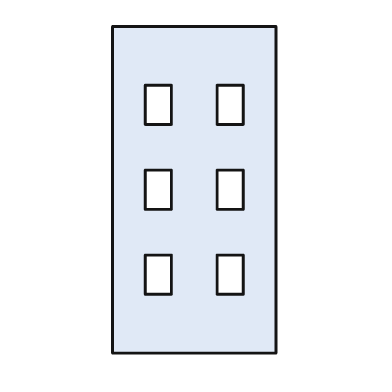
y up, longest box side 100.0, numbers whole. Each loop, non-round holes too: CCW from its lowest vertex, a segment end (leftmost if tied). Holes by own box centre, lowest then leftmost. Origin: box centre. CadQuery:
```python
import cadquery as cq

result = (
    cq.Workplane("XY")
    .moveTo(-25.0, -50.0)
    .lineTo(25.0, -50.0)
    .lineTo(25.0, 50.0)
    .lineTo(-25.0, 50.0)
    .close()
    .moveTo(-15.0, -32.0)
    .lineTo(-7.0, -32.0)
    .lineTo(-7.0, -20.0)
    .lineTo(-15.0, -20.0)
    .close()
    .moveTo(7.0, -32.0)
    .lineTo(15.0, -32.0)
    .lineTo(15.0, -20.0)
    .lineTo(7.0, -20.0)
    .close()
    .moveTo(-15.0, -6.0)
    .lineTo(-7.0, -6.0)
    .lineTo(-7.0, 6.0)
    .lineTo(-15.0, 6.0)
    .close()
    .moveTo(7.0, -6.0)
    .lineTo(15.0, -6.0)
    .lineTo(15.0, 6.0)
    .lineTo(7.0, 6.0)
    .close()
    .moveTo(-15.0, 20.0)
    .lineTo(-7.0, 20.0)
    .lineTo(-7.0, 32.0)
    .lineTo(-15.0, 32.0)
    .close()
    .moveTo(7.0, 20.0)
    .lineTo(15.0, 20.0)
    .lineTo(15.0, 32.0)
    .lineTo(7.0, 32.0)
    .close()
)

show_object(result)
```